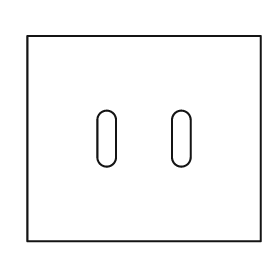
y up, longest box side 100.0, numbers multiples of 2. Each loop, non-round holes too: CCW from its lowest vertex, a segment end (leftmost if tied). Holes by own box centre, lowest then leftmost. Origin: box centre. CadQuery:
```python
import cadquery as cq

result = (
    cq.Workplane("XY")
    .moveTo(-50.0, -44.0)
    .lineTo(50.0, -44.0)
    .lineTo(50.0, 44.0)
    .lineTo(-50.0, 44.0)
    .close()
    .moveTo(-20.0, -8.0)
    .threePointArc((-16.0, -12.0), (-12.0, -8.0))
    .lineTo(-12.0, 8.0)
    .threePointArc((-16.0, 12.0), (-20.0, 8.0))
    .close()
    .moveTo(12.0, -8.0)
    .threePointArc((16.0, -12.0), (20.0, -8.0))
    .lineTo(20.0, 8.0)
    .threePointArc((16.0, 12.0), (12.0, 8.0))
    .close()
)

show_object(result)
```